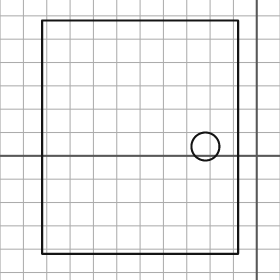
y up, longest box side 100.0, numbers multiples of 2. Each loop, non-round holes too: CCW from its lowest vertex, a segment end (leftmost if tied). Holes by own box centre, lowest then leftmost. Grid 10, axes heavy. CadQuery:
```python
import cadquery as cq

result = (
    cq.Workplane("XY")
    .moveTo(-92.0, -42.0)
    .lineTo(-8.0, -42.0)
    .lineTo(-8.0, 58.0)
    .lineTo(-92.0, 58.0)
    .close()
    .moveTo(-22.0, 4.0)
    .circle(6.0)
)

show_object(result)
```